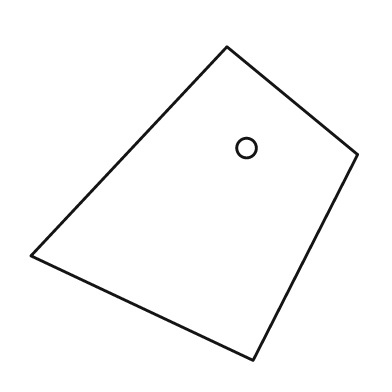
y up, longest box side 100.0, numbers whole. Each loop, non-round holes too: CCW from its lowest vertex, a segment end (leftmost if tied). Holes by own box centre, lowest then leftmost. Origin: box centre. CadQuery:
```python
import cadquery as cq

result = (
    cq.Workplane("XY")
    .moveTo(18.0, -48.0)
    .lineTo(50.0, 15.0)
    .lineTo(10.0, 48.0)
    .lineTo(-50.0, -16.0)
    .close()
    .moveTo(16.0, 17.0)
    .circle(3.0)
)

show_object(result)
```